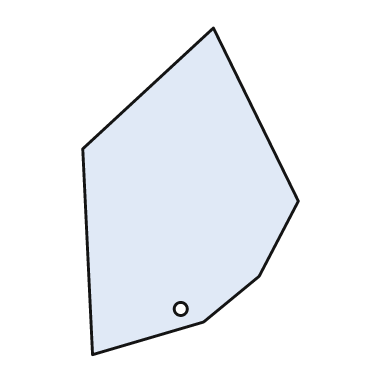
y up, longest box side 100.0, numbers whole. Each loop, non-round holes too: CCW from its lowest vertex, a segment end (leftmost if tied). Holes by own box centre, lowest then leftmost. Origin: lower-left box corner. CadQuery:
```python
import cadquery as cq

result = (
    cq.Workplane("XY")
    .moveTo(3.0, 0.0)
    .lineTo(37.0, 10.0)
    .lineTo(54.0, 24.0)
    .lineTo(66.0, 47.0)
    .lineTo(40.0, 100.0)
    .lineTo(0.0, 63.0)
    .close()
    .moveTo(30.0, 14.0)
    .circle(2.0)
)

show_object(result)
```